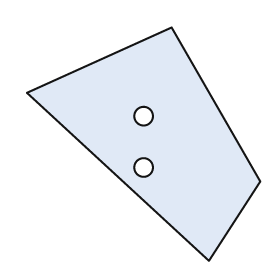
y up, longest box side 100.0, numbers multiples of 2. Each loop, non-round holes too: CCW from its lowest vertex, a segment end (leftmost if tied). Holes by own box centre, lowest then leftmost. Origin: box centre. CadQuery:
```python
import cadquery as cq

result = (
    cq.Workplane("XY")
    .moveTo(28.0, -50.0)
    .lineTo(50.0, -16.0)
    .lineTo(12.0, 50.0)
    .lineTo(-50.0, 22.0)
    .close()
    .moveTo(0.0, -10.0)
    .circle(4.0)
    .moveTo(0.0, 12.0)
    .circle(4.0)
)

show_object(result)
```